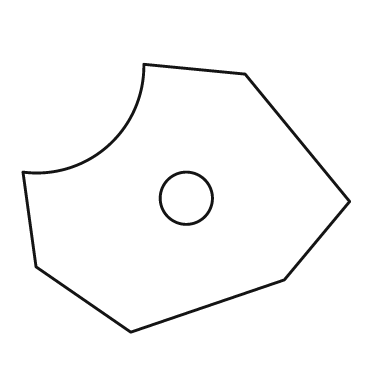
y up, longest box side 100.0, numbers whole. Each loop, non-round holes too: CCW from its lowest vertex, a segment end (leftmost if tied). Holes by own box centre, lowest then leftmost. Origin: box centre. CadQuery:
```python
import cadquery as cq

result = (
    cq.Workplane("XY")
    .moveTo(-17.0, -41.0)
    .lineTo(30.0, -25.0)
    .lineTo(50.0, -1.0)
    .lineTo(18.0, 38.0)
    .lineTo(-13.0, 41.0)
    .threePointArc((-24.0, 16.0), (-50.0, 8.0))
    .lineTo(-46.0, -21.0)
    .close()
    .moveTo(0.0, 0.0)
    .circle(8.0)
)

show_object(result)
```